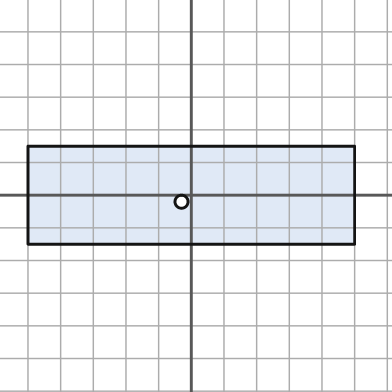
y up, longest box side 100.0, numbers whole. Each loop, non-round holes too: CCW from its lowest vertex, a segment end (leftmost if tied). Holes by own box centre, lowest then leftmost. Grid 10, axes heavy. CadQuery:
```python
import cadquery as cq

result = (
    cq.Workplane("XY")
    .moveTo(-50.0, -15.0)
    .lineTo(50.0, -15.0)
    .lineTo(50.0, 15.0)
    .lineTo(-50.0, 15.0)
    .close()
    .moveTo(-3.0, -2.0)
    .circle(2.0)
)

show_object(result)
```